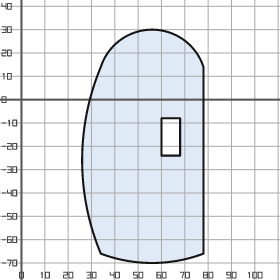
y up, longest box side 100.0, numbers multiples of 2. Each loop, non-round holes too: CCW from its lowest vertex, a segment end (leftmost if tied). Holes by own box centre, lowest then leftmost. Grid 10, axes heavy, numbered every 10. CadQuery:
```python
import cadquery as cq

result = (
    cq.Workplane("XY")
    .moveTo(34.0, -66.0)
    .threePointArc((56.0, -70.0), (78.0, -66.0))
    .lineTo(78.0, 14.0)
    .threePointArc((56.0, 30.0), (34.0, 14.0))
    .threePointArc((26.0, -26.0), (34.0, -66.0))
    .close()
    .moveTo(60.0, -24.0)
    .lineTo(68.0, -24.0)
    .lineTo(68.0, -8.0)
    .lineTo(60.0, -8.0)
    .close()
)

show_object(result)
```